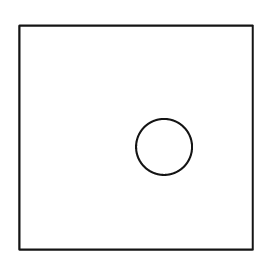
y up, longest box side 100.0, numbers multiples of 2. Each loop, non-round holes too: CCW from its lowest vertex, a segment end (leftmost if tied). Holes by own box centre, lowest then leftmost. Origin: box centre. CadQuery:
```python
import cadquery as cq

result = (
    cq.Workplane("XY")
    .moveTo(-50.0, -48.0)
    .lineTo(50.0, -48.0)
    .lineTo(50.0, 48.0)
    .lineTo(-50.0, 48.0)
    .close()
    .moveTo(12.0, -4.0)
    .circle(12.0)
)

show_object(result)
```